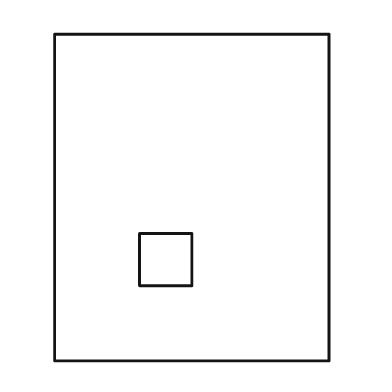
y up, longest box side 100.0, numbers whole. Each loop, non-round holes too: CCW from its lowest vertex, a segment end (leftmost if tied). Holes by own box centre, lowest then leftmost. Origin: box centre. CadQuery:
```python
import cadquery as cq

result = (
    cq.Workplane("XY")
    .moveTo(-42.0, -50.0)
    .lineTo(42.0, -50.0)
    .lineTo(42.0, 50.0)
    .lineTo(-42.0, 50.0)
    .close()
    .moveTo(-16.0, -27.0)
    .lineTo(0.0, -27.0)
    .lineTo(0.0, -11.0)
    .lineTo(-16.0, -11.0)
    .close()
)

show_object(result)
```